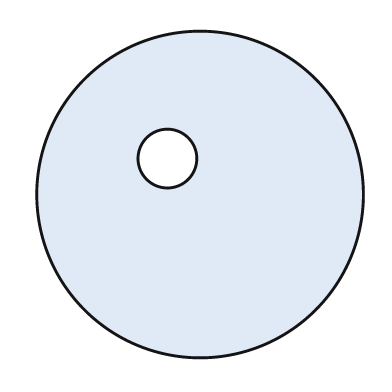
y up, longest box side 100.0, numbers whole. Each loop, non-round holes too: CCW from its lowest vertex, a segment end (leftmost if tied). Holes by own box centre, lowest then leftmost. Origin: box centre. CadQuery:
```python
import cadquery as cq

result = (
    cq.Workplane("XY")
    .moveTo(0.0, 0.0)
    .circle(50.0)
    .moveTo(-10.0, 11.0)
    .circle(9.0)
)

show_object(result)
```